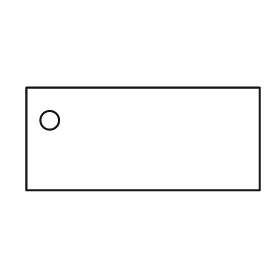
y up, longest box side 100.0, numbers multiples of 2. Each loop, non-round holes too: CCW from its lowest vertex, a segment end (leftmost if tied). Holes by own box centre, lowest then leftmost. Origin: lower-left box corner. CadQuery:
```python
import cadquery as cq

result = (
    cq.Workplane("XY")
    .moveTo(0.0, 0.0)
    .lineTo(100.0, 0.0)
    .lineTo(100.0, 44.0)
    .lineTo(0.0, 44.0)
    .close()
    .moveTo(10.0, 30.0)
    .circle(4.0)
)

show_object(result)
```